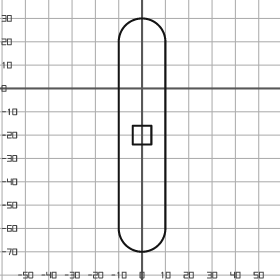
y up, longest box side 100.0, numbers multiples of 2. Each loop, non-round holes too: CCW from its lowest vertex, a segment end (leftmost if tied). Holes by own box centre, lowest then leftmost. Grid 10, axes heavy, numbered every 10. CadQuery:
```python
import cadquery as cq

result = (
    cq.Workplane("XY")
    .moveTo(-10.0, -60.0)
    .threePointArc((0.0, -70.0), (10.0, -60.0))
    .lineTo(10.0, 20.0)
    .threePointArc((0.0, 30.0), (-10.0, 20.0))
    .close()
    .moveTo(-4.0, -24.0)
    .lineTo(4.0, -24.0)
    .lineTo(4.0, -16.0)
    .lineTo(-4.0, -16.0)
    .close()
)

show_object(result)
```